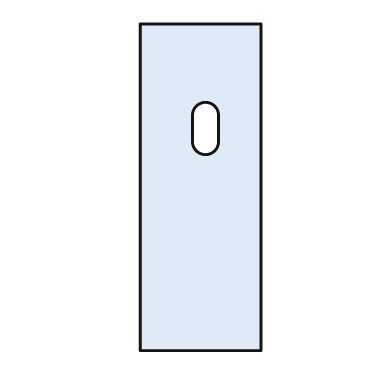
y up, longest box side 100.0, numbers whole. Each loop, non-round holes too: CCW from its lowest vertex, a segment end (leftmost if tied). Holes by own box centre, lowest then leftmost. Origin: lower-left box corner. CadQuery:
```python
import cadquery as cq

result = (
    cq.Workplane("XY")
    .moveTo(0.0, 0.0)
    .lineTo(37.0, 0.0)
    .lineTo(37.0, 100.0)
    .lineTo(0.0, 100.0)
    .close()
    .moveTo(16.0, 64.0)
    .threePointArc((20.0, 60.0), (24.0, 64.0))
    .lineTo(24.0, 72.0)
    .threePointArc((20.0, 76.0), (16.0, 72.0))
    .close()
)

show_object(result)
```